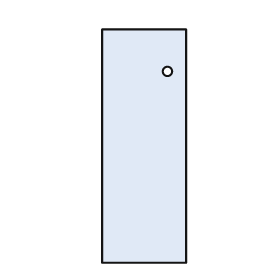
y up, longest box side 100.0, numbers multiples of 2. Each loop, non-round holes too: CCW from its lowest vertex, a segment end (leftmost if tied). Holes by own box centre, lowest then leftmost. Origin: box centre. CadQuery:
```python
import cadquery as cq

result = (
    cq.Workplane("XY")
    .moveTo(-18.0, -50.0)
    .lineTo(18.0, -50.0)
    .lineTo(18.0, 50.0)
    .lineTo(-18.0, 50.0)
    .close()
    .moveTo(10.0, 32.0)
    .circle(2.0)
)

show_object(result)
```